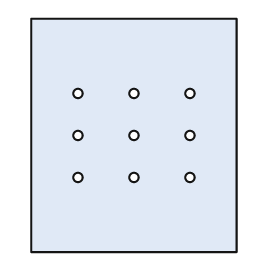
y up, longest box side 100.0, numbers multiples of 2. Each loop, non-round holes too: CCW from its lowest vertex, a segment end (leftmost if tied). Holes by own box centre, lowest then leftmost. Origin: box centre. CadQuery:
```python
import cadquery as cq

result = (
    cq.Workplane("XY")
    .moveTo(-44.0, -50.0)
    .lineTo(44.0, -50.0)
    .lineTo(44.0, 50.0)
    .lineTo(-44.0, 50.0)
    .close()
    .moveTo(-24.0, -18.0)
    .circle(2.0)
    .moveTo(0.0, -18.0)
    .circle(2.0)
    .moveTo(24.0, -18.0)
    .circle(2.0)
    .moveTo(-24.0, 0.0)
    .circle(2.0)
    .moveTo(0.0, 0.0)
    .circle(2.0)
    .moveTo(24.0, 0.0)
    .circle(2.0)
    .moveTo(-24.0, 18.0)
    .circle(2.0)
    .moveTo(0.0, 18.0)
    .circle(2.0)
    .moveTo(24.0, 18.0)
    .circle(2.0)
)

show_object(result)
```